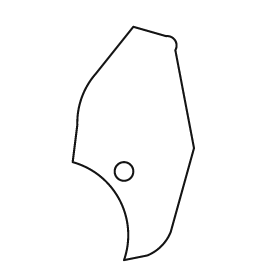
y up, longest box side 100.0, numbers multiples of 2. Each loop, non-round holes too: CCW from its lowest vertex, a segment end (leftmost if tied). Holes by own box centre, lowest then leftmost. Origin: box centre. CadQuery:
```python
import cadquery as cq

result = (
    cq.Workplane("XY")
    .moveTo(-4.0, -50.0)
    .lineTo(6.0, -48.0)
    .threePointArc((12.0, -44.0), (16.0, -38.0))
    .lineTo(26.0, -2.0)
    .lineTo(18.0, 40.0)
    .threePointArc((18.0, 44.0), (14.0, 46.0))
    .lineTo(0.0, 50.0)
    .lineTo(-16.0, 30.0)
    .threePointArc((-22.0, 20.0), (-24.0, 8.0))
    .lineTo(-26.0, -8.0)
    .threePointArc((-6.0, -24.0), (-4.0, -50.0))
    .close()
    .moveTo(-4.0, -12.0)
    .circle(4.0)
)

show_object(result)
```